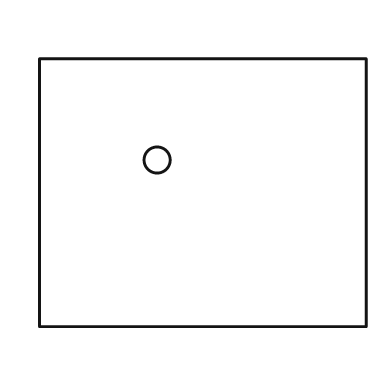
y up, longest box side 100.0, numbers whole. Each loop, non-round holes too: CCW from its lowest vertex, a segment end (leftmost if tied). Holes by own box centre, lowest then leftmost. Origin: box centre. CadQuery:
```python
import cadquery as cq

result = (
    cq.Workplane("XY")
    .moveTo(-50.0, -41.0)
    .lineTo(50.0, -41.0)
    .lineTo(50.0, 41.0)
    .lineTo(-50.0, 41.0)
    .close()
    .moveTo(-14.0, 10.0)
    .circle(4.0)
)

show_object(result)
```